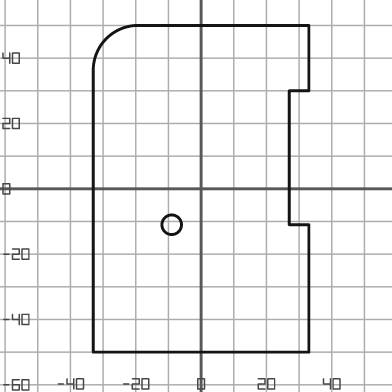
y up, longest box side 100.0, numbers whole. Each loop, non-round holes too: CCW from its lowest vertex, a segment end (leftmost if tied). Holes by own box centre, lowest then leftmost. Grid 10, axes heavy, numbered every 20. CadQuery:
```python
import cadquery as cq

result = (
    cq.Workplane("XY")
    .moveTo(-33.0, -50.0)
    .lineTo(33.0, -50.0)
    .lineTo(33.0, -11.0)
    .lineTo(27.0, -11.0)
    .lineTo(27.0, 30.0)
    .lineTo(33.0, 30.0)
    .lineTo(33.0, 50.0)
    .lineTo(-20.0, 50.0)
    .threePointArc((-29.0, 46.0), (-33.0, 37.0))
    .close()
    .moveTo(-9.0, -11.0)
    .circle(3.0)
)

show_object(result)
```